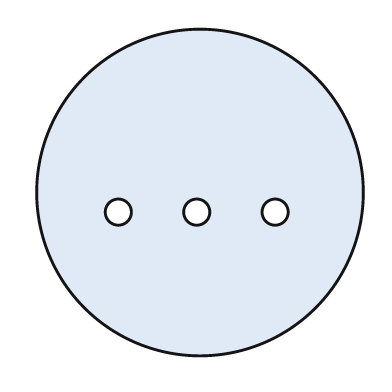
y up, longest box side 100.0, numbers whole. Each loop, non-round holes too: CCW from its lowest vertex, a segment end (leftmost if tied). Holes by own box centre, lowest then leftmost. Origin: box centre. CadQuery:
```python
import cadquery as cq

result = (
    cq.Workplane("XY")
    .moveTo(0.0, 0.0)
    .circle(50.0)
    .moveTo(-25.0, -6.0)
    .circle(4.0)
    .moveTo(-1.0, -6.0)
    .circle(4.0)
    .moveTo(23.0, -6.0)
    .circle(4.0)
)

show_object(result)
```